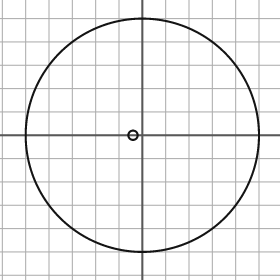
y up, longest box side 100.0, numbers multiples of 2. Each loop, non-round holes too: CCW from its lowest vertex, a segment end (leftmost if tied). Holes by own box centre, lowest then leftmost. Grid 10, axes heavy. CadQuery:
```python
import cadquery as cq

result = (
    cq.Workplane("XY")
    .moveTo(0.0, 0.0)
    .circle(50.0)
    .moveTo(-4.0, 0.0)
    .circle(2.0)
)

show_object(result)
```